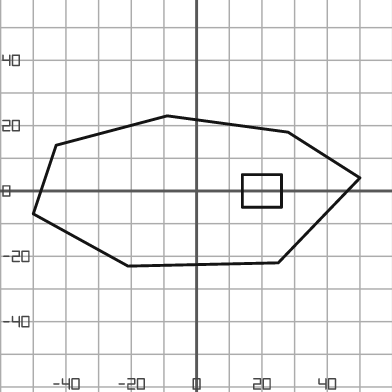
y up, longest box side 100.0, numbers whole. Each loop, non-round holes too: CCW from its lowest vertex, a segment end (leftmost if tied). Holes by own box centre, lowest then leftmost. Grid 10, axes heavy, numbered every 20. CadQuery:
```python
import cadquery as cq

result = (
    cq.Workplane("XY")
    .moveTo(-21.0, -23.0)
    .lineTo(25.0, -22.0)
    .lineTo(50.0, 4.0)
    .lineTo(28.0, 18.0)
    .lineTo(-9.0, 23.0)
    .lineTo(-43.0, 14.0)
    .lineTo(-50.0, -7.0)
    .close()
    .moveTo(14.0, -5.0)
    .lineTo(26.0, -5.0)
    .lineTo(26.0, 5.0)
    .lineTo(14.0, 5.0)
    .close()
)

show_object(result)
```